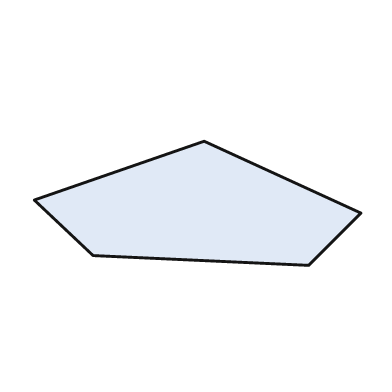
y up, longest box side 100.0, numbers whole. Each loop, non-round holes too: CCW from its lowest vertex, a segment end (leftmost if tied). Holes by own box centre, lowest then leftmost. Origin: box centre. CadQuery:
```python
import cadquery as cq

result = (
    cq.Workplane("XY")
    .moveTo(34.0, -19.0)
    .lineTo(50.0, -3.0)
    .lineTo(2.0, 19.0)
    .lineTo(-50.0, 1.0)
    .lineTo(-32.0, -16.0)
    .close()
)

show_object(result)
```